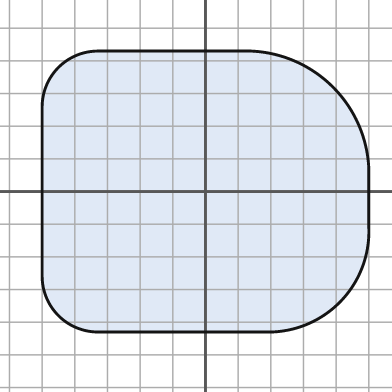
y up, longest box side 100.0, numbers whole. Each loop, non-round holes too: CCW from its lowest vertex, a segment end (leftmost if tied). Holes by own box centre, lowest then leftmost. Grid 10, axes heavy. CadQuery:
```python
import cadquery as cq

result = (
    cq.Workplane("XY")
    .moveTo(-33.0, -43.0)
    .lineTo(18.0, -43.0)
    .threePointArc((41.0, -34.0), (50.0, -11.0))
    .lineTo(50.0, 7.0)
    .threePointArc((39.0, 32.0), (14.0, 43.0))
    .lineTo(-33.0, 43.0)
    .threePointArc((-45.0, 38.0), (-50.0, 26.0))
    .lineTo(-50.0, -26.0)
    .threePointArc((-45.0, -38.0), (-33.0, -43.0))
    .close()
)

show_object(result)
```